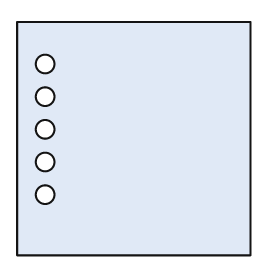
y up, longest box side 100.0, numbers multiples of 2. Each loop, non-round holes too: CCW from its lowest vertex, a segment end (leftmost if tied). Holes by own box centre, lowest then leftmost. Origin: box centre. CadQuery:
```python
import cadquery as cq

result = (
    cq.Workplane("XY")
    .moveTo(-50.0, -50.0)
    .lineTo(50.0, -50.0)
    .lineTo(50.0, 50.0)
    .lineTo(-50.0, 50.0)
    .close()
    .moveTo(-38.0, -24.0)
    .circle(4.0)
    .moveTo(-38.0, -10.0)
    .circle(4.0)
    .moveTo(-38.0, 4.0)
    .circle(4.0)
    .moveTo(-38.0, 18.0)
    .circle(4.0)
    .moveTo(-38.0, 32.0)
    .circle(4.0)
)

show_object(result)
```